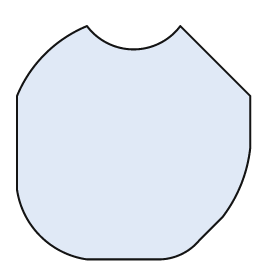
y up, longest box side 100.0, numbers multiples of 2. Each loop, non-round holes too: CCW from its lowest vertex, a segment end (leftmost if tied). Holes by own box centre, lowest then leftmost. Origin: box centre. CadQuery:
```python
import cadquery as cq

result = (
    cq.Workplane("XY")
    .moveTo(-20.0, -50.0)
    .lineTo(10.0, -50.0)
    .threePointArc((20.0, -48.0), (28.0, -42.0))
    .lineTo(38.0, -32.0)
    .threePointArc((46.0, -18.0), (50.0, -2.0))
    .lineTo(50.0, 20.0)
    .lineTo(20.0, 50.0)
    .threePointArc((0.0, 40.0), (-20.0, 50.0))
    .threePointArc((-38.0, 38.0), (-50.0, 20.0))
    .lineTo(-50.0, -20.0)
    .threePointArc((-40.0, -40.0), (-20.0, -50.0))
    .close()
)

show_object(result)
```